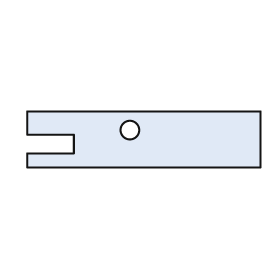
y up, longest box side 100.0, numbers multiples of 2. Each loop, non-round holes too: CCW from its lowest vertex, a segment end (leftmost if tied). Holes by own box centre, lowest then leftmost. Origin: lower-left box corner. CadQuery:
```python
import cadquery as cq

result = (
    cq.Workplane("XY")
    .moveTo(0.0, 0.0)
    .lineTo(100.0, 0.0)
    .lineTo(100.0, 24.0)
    .lineTo(0.0, 24.0)
    .lineTo(0.0, 14.0)
    .lineTo(20.0, 14.0)
    .lineTo(20.0, 6.0)
    .lineTo(0.0, 6.0)
    .close()
    .moveTo(44.0, 16.0)
    .circle(4.0)
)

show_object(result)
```